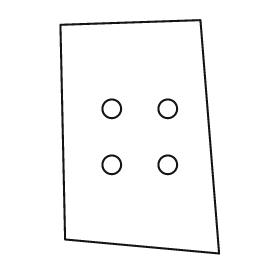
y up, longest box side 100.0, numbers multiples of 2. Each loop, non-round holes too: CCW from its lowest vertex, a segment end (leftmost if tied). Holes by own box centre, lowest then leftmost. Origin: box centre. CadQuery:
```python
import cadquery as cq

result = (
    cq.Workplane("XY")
    .moveTo(34.0, -50.0)
    .lineTo(26.0, 50.0)
    .lineTo(-34.0, 48.0)
    .lineTo(-32.0, -44.0)
    .close()
    .moveTo(-12.0, -12.0)
    .circle(4.0)
    .moveTo(12.0, -12.0)
    .circle(4.0)
    .moveTo(-12.0, 12.0)
    .circle(4.0)
    .moveTo(12.0, 12.0)
    .circle(4.0)
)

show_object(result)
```